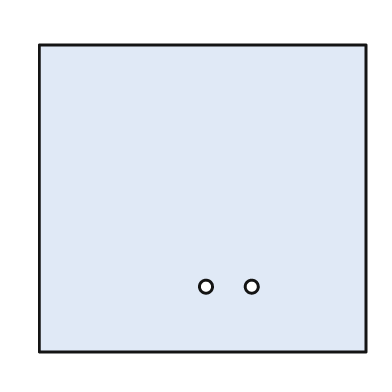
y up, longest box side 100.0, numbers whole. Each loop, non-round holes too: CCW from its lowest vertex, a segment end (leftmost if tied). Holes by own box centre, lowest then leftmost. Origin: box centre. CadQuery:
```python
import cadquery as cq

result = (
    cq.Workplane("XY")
    .moveTo(-50.0, -47.0)
    .lineTo(50.0, -47.0)
    .lineTo(50.0, 47.0)
    .lineTo(-50.0, 47.0)
    .close()
    .moveTo(1.0, -27.0)
    .circle(2.0)
    .moveTo(15.0, -27.0)
    .circle(2.0)
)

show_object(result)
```